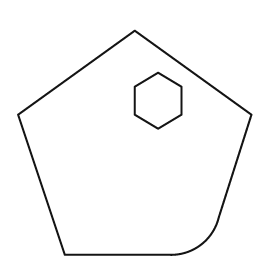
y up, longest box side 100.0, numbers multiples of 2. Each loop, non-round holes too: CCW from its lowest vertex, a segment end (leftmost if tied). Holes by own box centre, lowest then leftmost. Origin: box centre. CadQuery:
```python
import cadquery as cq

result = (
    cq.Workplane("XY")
    .moveTo(-30.0, -48.0)
    .lineTo(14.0, -48.0)
    .threePointArc((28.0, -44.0), (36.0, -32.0))
    .lineTo(50.0, 12.0)
    .lineTo(0.0, 48.0)
    .lineTo(-50.0, 12.0)
    .close()
    .moveTo(10.0, 6.0)
    .lineTo(20.0, 12.0)
    .lineTo(20.0, 24.0)
    .lineTo(10.0, 30.0)
    .lineTo(0.0, 24.0)
    .lineTo(0.0, 12.0)
    .close()
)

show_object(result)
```